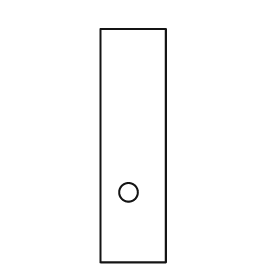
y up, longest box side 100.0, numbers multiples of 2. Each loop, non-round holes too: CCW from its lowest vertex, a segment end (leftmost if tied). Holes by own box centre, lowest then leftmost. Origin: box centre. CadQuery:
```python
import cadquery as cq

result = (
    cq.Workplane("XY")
    .moveTo(-14.0, -50.0)
    .lineTo(14.0, -50.0)
    .lineTo(14.0, 50.0)
    .lineTo(-14.0, 50.0)
    .close()
    .moveTo(-2.0, -20.0)
    .circle(4.0)
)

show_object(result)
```